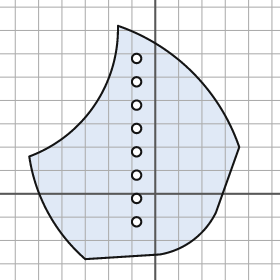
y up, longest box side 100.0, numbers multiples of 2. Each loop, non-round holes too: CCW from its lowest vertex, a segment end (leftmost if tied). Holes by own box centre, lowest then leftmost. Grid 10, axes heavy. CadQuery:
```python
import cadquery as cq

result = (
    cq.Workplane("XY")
    .moveTo(-30.0, -28.0)
    .lineTo(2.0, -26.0)
    .threePointArc((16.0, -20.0), (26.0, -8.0))
    .lineTo(36.0, 20.0)
    .threePointArc((16.0, 52.0), (-16.0, 72.0))
    .threePointArc((-26.0, 38.0), (-54.0, 16.0))
    .threePointArc((-46.0, -8.0), (-30.0, -28.0))
    .close()
    .moveTo(-8.0, -12.0)
    .circle(2.0)
    .moveTo(-8.0, -2.0)
    .circle(2.0)
    .moveTo(-8.0, 8.0)
    .circle(2.0)
    .moveTo(-8.0, 18.0)
    .circle(2.0)
    .moveTo(-8.0, 28.0)
    .circle(2.0)
    .moveTo(-8.0, 38.0)
    .circle(2.0)
    .moveTo(-8.0, 48.0)
    .circle(2.0)
    .moveTo(-8.0, 58.0)
    .circle(2.0)
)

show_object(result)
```